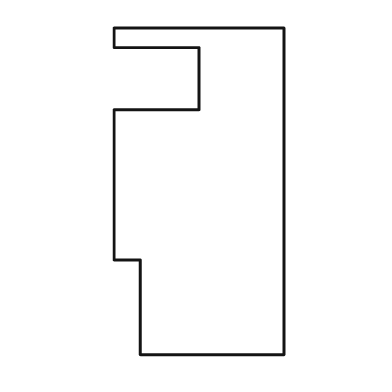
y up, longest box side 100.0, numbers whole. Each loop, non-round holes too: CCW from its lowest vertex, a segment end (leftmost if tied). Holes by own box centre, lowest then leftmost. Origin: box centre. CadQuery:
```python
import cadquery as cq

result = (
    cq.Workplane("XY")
    .moveTo(-18.0, -50.0)
    .lineTo(26.0, -50.0)
    .lineTo(26.0, 50.0)
    .lineTo(-26.0, 50.0)
    .lineTo(-26.0, 44.0)
    .lineTo(0.0, 44.0)
    .lineTo(0.0, 25.0)
    .lineTo(-26.0, 25.0)
    .lineTo(-26.0, -21.0)
    .lineTo(-18.0, -21.0)
    .close()
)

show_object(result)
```